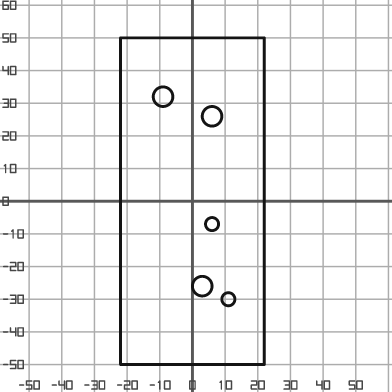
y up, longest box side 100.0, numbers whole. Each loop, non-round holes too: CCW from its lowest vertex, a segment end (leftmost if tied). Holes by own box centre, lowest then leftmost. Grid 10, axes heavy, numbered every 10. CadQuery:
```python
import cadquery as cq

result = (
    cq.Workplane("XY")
    .moveTo(-22.0, -50.0)
    .lineTo(22.0, -50.0)
    .lineTo(22.0, 50.0)
    .lineTo(-22.0, 50.0)
    .close()
    .moveTo(11.0, -30.0)
    .circle(2.0)
    .moveTo(3.0, -26.0)
    .circle(3.0)
    .moveTo(6.0, -7.0)
    .circle(2.0)
    .moveTo(6.0, 26.0)
    .circle(3.0)
    .moveTo(-9.0, 32.0)
    .circle(3.0)
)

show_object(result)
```